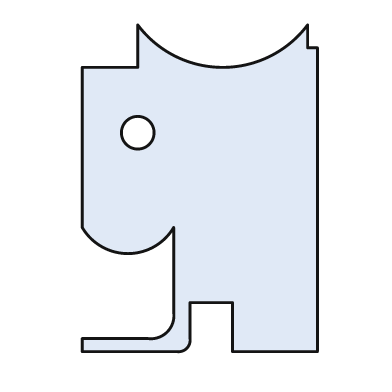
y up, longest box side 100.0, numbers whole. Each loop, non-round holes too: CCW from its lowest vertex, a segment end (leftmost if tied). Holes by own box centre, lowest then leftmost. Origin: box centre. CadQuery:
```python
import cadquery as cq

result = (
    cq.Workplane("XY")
    .moveTo(-36.0, -50.0)
    .lineTo(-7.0, -50.0)
    .threePointArc((-4.0, -49.0), (-3.0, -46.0))
    .lineTo(-3.0, -35.0)
    .lineTo(10.0, -35.0)
    .lineTo(10.0, -50.0)
    .lineTo(36.0, -50.0)
    .lineTo(36.0, 43.0)
    .lineTo(33.0, 43.0)
    .lineTo(33.0, 50.0)
    .threePointArc((7.0, 37.0), (-19.0, 50.0))
    .lineTo(-19.0, 37.0)
    .lineTo(-36.0, 37.0)
    .lineTo(-36.0, -12.0)
    .threePointArc((-22.0, -20.0), (-8.0, -12.0))
    .lineTo(-8.0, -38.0)
    .threePointArc((-10.0, -44.0), (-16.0, -46.0))
    .lineTo(-36.0, -46.0)
    .close()
    .moveTo(-19.0, 17.0)
    .circle(5.0)
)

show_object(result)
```